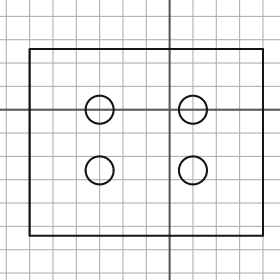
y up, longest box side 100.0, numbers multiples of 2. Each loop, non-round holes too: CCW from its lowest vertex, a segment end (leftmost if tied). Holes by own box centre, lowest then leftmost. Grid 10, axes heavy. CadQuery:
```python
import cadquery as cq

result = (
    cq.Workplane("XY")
    .moveTo(-60.0, -54.0)
    .lineTo(40.0, -54.0)
    .lineTo(40.0, 26.0)
    .lineTo(-60.0, 26.0)
    .close()
    .moveTo(-30.0, -26.0)
    .circle(6.0)
    .moveTo(10.0, -26.0)
    .circle(6.0)
    .moveTo(-30.0, 0.0)
    .circle(6.0)
    .moveTo(10.0, 0.0)
    .circle(6.0)
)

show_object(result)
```